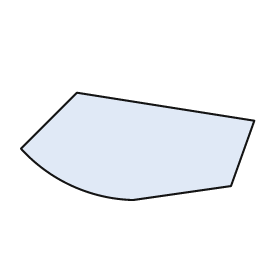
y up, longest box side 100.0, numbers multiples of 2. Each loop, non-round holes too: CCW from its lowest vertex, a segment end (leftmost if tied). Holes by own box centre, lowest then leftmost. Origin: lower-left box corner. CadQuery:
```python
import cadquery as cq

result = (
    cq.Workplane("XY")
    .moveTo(48.0, 0.0)
    .lineTo(90.0, 6.0)
    .lineTo(100.0, 34.0)
    .lineTo(24.0, 46.0)
    .lineTo(0.0, 22.0)
    .threePointArc((22.0, 6.0), (48.0, 0.0))
    .close()
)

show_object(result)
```